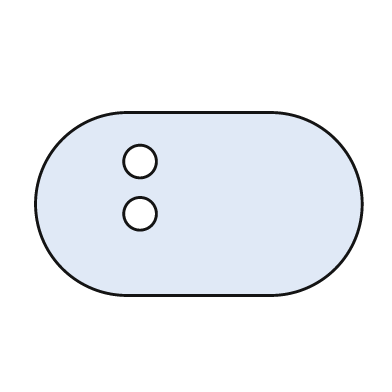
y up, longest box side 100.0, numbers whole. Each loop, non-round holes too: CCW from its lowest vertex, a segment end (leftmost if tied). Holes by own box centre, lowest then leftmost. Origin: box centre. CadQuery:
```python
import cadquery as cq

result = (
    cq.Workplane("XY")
    .moveTo(-22.0, -28.0)
    .lineTo(22.0, -28.0)
    .threePointArc((50.0, 0.0), (22.0, 28.0))
    .lineTo(-22.0, 28.0)
    .threePointArc((-50.0, 0.0), (-22.0, -28.0))
    .close()
    .moveTo(-18.0, -3.0)
    .circle(5.0)
    .moveTo(-18.0, 13.0)
    .circle(5.0)
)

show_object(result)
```